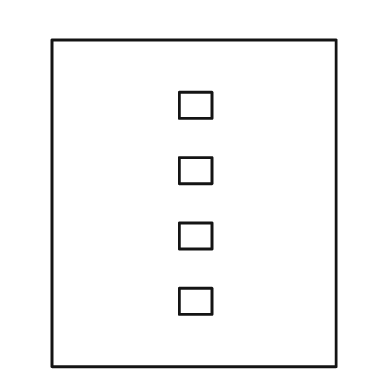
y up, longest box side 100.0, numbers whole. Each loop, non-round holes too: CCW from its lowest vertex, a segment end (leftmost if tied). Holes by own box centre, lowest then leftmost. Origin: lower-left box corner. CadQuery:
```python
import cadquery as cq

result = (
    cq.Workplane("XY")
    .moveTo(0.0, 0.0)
    .lineTo(87.0, 0.0)
    .lineTo(87.0, 100.0)
    .lineTo(0.0, 100.0)
    .close()
    .moveTo(39.0, 16.0)
    .lineTo(49.0, 16.0)
    .lineTo(49.0, 24.0)
    .lineTo(39.0, 24.0)
    .close()
    .moveTo(39.0, 36.0)
    .lineTo(49.0, 36.0)
    .lineTo(49.0, 44.0)
    .lineTo(39.0, 44.0)
    .close()
    .moveTo(39.0, 56.0)
    .lineTo(49.0, 56.0)
    .lineTo(49.0, 64.0)
    .lineTo(39.0, 64.0)
    .close()
    .moveTo(39.0, 76.0)
    .lineTo(49.0, 76.0)
    .lineTo(49.0, 84.0)
    .lineTo(39.0, 84.0)
    .close()
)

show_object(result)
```